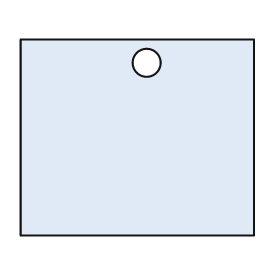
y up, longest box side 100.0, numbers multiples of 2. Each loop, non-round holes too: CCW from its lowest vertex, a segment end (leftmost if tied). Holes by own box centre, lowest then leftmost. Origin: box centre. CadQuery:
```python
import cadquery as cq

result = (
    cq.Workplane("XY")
    .moveTo(-50.0, -42.0)
    .lineTo(50.0, -42.0)
    .lineTo(50.0, 42.0)
    .lineTo(-50.0, 42.0)
    .close()
    .moveTo(4.0, 32.0)
    .circle(6.0)
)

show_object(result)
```